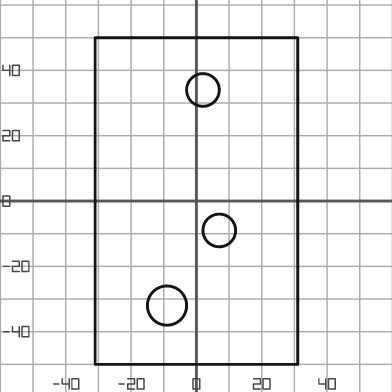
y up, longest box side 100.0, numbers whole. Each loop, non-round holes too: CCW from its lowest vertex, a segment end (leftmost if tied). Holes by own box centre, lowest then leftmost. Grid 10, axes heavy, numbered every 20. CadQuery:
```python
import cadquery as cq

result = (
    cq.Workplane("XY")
    .moveTo(-31.0, -50.0)
    .lineTo(31.0, -50.0)
    .lineTo(31.0, 50.0)
    .lineTo(-31.0, 50.0)
    .close()
    .moveTo(-9.0, -32.0)
    .circle(6.0)
    .moveTo(7.0, -9.0)
    .circle(5.0)
    .moveTo(2.0, 34.0)
    .circle(5.0)
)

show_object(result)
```